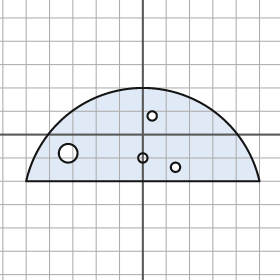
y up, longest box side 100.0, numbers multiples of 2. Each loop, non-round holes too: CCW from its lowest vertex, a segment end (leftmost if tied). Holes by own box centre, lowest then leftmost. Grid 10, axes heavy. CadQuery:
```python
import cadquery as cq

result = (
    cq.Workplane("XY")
    .moveTo(-50.0, -20.0)
    .lineTo(50.0, -20.0)
    .threePointArc((0.0, 20.0), (-50.0, -20.0))
    .close()
    .moveTo(14.0, -14.0)
    .circle(2.0)
    .moveTo(0.0, -10.0)
    .circle(2.0)
    .moveTo(-32.0, -8.0)
    .circle(4.0)
    .moveTo(4.0, 8.0)
    .circle(2.0)
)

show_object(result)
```